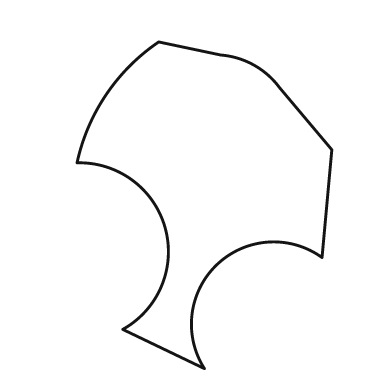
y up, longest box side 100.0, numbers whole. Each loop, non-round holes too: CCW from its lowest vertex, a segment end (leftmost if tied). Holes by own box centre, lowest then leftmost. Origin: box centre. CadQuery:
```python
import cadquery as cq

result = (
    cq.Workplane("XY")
    .moveTo(0.0, -50.0)
    .threePointArc((4.0, -18.0), (36.0, -16.0))
    .lineTo(39.0, 17.0)
    .lineTo(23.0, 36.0)
    .threePointArc((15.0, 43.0), (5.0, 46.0))
    .lineTo(-14.0, 50.0)
    .threePointArc((-30.0, 34.0), (-39.0, 13.0))
    .threePointArc((-12.0, -7.0), (-25.0, -38.0))
    .close()
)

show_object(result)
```